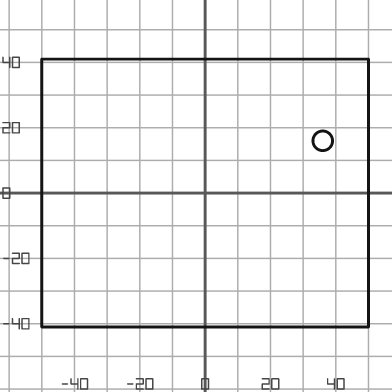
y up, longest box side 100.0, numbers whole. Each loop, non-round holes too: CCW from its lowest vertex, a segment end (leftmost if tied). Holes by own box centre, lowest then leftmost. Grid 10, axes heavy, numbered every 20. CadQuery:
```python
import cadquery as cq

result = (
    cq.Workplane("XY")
    .moveTo(-50.0, -41.0)
    .lineTo(50.0, -41.0)
    .lineTo(50.0, 41.0)
    .lineTo(-50.0, 41.0)
    .close()
    .moveTo(36.0, 16.0)
    .circle(3.0)
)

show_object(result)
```